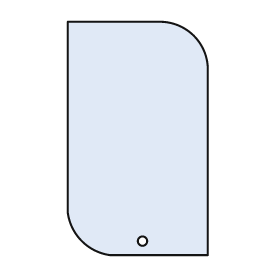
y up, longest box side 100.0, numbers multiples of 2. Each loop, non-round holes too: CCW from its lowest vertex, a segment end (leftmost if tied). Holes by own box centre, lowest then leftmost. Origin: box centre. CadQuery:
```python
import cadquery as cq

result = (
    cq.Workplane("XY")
    .moveTo(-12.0, -50.0)
    .lineTo(30.0, -50.0)
    .lineTo(30.0, 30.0)
    .threePointArc((24.0, 44.0), (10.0, 50.0))
    .lineTo(-30.0, 50.0)
    .lineTo(-30.0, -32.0)
    .threePointArc((-24.0, -44.0), (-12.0, -50.0))
    .close()
    .moveTo(2.0, -44.0)
    .circle(2.0)
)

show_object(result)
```